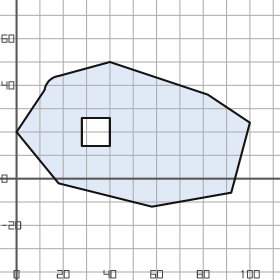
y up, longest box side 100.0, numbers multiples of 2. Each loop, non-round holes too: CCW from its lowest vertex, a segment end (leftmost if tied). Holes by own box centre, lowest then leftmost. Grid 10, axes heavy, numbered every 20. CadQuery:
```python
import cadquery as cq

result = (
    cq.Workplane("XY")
    .moveTo(58.0, -12.0)
    .lineTo(92.0, -6.0)
    .lineTo(100.0, 24.0)
    .lineTo(82.0, 36.0)
    .lineTo(40.0, 50.0)
    .lineTo(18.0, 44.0)
    .threePointArc((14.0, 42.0), (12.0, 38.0))
    .lineTo(0.0, 20.0)
    .lineTo(18.0, -2.0)
    .close()
    .moveTo(28.0, 14.0)
    .lineTo(40.0, 14.0)
    .lineTo(40.0, 26.0)
    .lineTo(28.0, 26.0)
    .close()
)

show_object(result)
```